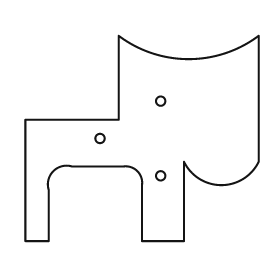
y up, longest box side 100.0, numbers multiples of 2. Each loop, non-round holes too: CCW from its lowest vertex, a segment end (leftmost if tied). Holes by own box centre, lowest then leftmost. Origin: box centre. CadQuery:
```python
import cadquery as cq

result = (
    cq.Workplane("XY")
    .moveTo(-50.0, -44.0)
    .lineTo(-40.0, -44.0)
    .lineTo(-40.0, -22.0)
    .threePointArc((-38.0, -14.0), (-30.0, -12.0))
    .lineTo(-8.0, -12.0)
    .threePointArc((-2.0, -14.0), (0.0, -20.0))
    .lineTo(0.0, -44.0)
    .lineTo(18.0, -44.0)
    .lineTo(18.0, -10.0)
    .threePointArc((34.0, -20.0), (50.0, -10.0))
    .lineTo(50.0, 44.0)
    .threePointArc((20.0, 34.0), (-10.0, 44.0))
    .lineTo(-10.0, 8.0)
    .lineTo(-50.0, 8.0)
    .close()
    .moveTo(8.0, -16.0)
    .circle(2.0)
    .moveTo(-18.0, 0.0)
    .circle(2.0)
    .moveTo(8.0, 16.0)
    .circle(2.0)
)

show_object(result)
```